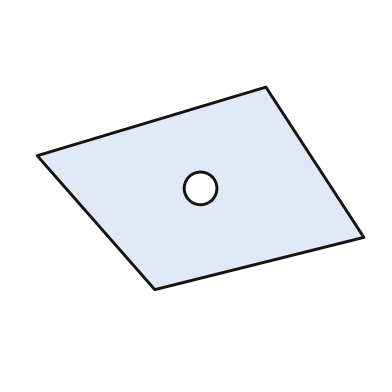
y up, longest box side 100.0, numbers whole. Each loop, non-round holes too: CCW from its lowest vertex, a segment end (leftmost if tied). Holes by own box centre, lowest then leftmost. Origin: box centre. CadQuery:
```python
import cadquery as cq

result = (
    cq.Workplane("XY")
    .moveTo(-14.0, -31.0)
    .lineTo(50.0, -15.0)
    .lineTo(20.0, 31.0)
    .lineTo(-50.0, 10.0)
    .close()
    .moveTo(0.0, 0.0)
    .circle(5.0)
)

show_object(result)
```